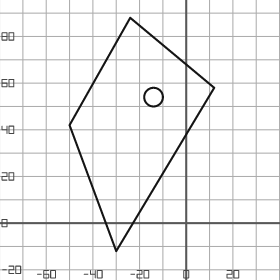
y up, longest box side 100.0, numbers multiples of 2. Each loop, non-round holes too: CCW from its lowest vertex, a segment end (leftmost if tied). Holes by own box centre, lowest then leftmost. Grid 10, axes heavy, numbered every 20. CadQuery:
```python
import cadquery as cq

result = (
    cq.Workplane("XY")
    .moveTo(-30.0, -12.0)
    .lineTo(12.0, 58.0)
    .lineTo(-24.0, 88.0)
    .lineTo(-50.0, 42.0)
    .close()
    .moveTo(-14.0, 54.0)
    .circle(4.0)
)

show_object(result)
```